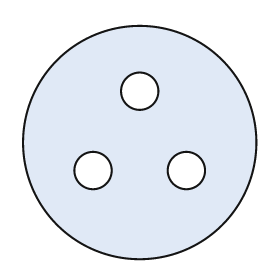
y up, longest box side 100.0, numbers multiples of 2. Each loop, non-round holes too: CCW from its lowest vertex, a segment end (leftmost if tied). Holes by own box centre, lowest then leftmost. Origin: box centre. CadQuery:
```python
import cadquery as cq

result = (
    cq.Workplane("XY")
    .moveTo(0.0, 0.0)
    .circle(50.0)
    .moveTo(-20.0, -12.0)
    .circle(8.0)
    .moveTo(20.0, -12.0)
    .circle(8.0)
    .moveTo(0.0, 22.0)
    .circle(8.0)
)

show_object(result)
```